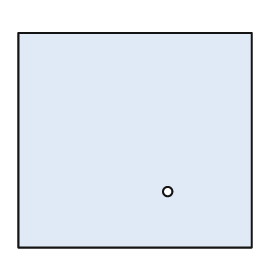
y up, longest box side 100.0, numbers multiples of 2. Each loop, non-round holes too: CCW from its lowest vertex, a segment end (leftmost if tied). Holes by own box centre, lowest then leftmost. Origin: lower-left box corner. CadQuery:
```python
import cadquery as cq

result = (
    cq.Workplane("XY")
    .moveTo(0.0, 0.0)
    .lineTo(100.0, 0.0)
    .lineTo(100.0, 92.0)
    .lineTo(0.0, 92.0)
    .close()
    .moveTo(64.0, 24.0)
    .circle(2.0)
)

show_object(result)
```